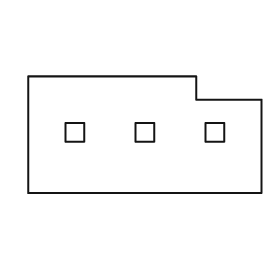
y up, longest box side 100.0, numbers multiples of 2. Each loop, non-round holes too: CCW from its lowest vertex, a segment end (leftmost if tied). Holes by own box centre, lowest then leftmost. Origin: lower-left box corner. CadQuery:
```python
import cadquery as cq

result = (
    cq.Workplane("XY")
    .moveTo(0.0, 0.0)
    .lineTo(100.0, 0.0)
    .lineTo(100.0, 40.0)
    .lineTo(72.0, 40.0)
    .lineTo(72.0, 50.0)
    .lineTo(0.0, 50.0)
    .close()
    .moveTo(16.0, 22.0)
    .lineTo(24.0, 22.0)
    .lineTo(24.0, 30.0)
    .lineTo(16.0, 30.0)
    .close()
    .moveTo(46.0, 22.0)
    .lineTo(54.0, 22.0)
    .lineTo(54.0, 30.0)
    .lineTo(46.0, 30.0)
    .close()
    .moveTo(76.0, 22.0)
    .lineTo(84.0, 22.0)
    .lineTo(84.0, 30.0)
    .lineTo(76.0, 30.0)
    .close()
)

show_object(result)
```